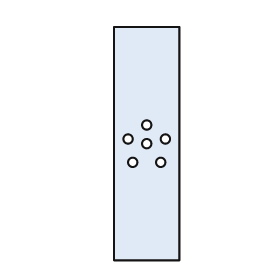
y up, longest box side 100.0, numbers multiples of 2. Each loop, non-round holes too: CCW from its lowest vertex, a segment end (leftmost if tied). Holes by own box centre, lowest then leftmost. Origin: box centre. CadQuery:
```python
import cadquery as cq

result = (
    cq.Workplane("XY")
    .moveTo(-14.0, -50.0)
    .lineTo(14.0, -50.0)
    .lineTo(14.0, 50.0)
    .lineTo(-14.0, 50.0)
    .close()
    .moveTo(-6.0, -8.0)
    .circle(2.0)
    .moveTo(6.0, -8.0)
    .circle(2.0)
    .moveTo(0.0, 0.0)
    .circle(2.0)
    .moveTo(-8.0, 2.0)
    .circle(2.0)
    .moveTo(8.0, 2.0)
    .circle(2.0)
    .moveTo(0.0, 8.0)
    .circle(2.0)
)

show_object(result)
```